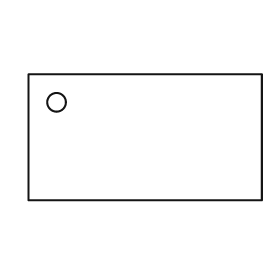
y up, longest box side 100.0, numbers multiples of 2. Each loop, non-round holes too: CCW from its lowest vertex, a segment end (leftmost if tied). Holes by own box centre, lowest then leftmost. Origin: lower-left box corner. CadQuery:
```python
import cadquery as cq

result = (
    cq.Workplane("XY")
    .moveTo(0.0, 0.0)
    .lineTo(100.0, 0.0)
    .lineTo(100.0, 54.0)
    .lineTo(0.0, 54.0)
    .close()
    .moveTo(12.0, 42.0)
    .circle(4.0)
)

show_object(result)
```